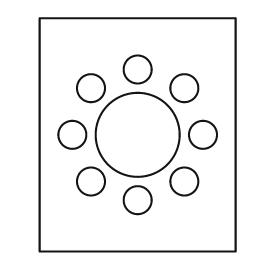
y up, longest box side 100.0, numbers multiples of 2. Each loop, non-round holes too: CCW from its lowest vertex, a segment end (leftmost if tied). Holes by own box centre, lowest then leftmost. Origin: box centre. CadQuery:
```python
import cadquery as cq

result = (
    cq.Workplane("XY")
    .moveTo(-42.0, -50.0)
    .lineTo(42.0, -50.0)
    .lineTo(42.0, 50.0)
    .lineTo(-42.0, 50.0)
    .close()
    .moveTo(0.0, -28.0)
    .circle(6.0)
    .moveTo(-20.0, -20.0)
    .circle(6.0)
    .moveTo(20.0, -20.0)
    .circle(6.0)
    .moveTo(-28.0, 0.0)
    .circle(6.0)
    .moveTo(0.0, 0.0)
    .circle(18.0)
    .moveTo(28.0, 0.0)
    .circle(6.0)
    .moveTo(-20.0, 20.0)
    .circle(6.0)
    .moveTo(20.0, 20.0)
    .circle(6.0)
    .moveTo(0.0, 28.0)
    .circle(6.0)
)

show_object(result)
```